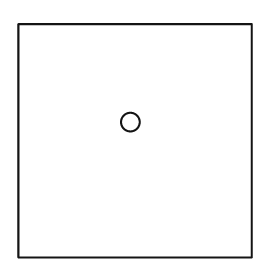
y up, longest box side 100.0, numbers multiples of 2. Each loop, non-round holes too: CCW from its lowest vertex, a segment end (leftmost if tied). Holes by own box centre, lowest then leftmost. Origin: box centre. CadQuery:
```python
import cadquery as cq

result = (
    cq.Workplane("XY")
    .moveTo(-50.0, -50.0)
    .lineTo(50.0, -50.0)
    .lineTo(50.0, 50.0)
    .lineTo(-50.0, 50.0)
    .close()
    .moveTo(-2.0, 8.0)
    .circle(4.0)
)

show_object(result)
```